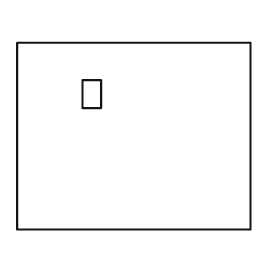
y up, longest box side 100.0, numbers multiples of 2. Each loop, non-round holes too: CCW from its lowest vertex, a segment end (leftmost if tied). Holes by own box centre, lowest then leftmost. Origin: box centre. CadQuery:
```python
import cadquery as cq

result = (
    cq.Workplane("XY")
    .moveTo(-50.0, -40.0)
    .lineTo(50.0, -40.0)
    .lineTo(50.0, 40.0)
    .lineTo(-50.0, 40.0)
    .close()
    .moveTo(-22.0, 12.0)
    .lineTo(-14.0, 12.0)
    .lineTo(-14.0, 24.0)
    .lineTo(-22.0, 24.0)
    .close()
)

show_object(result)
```